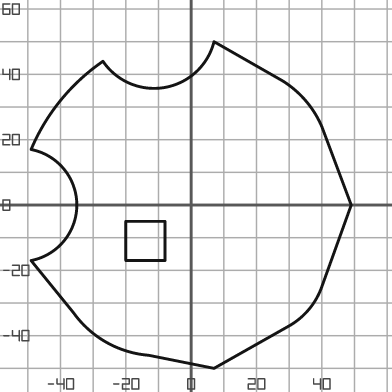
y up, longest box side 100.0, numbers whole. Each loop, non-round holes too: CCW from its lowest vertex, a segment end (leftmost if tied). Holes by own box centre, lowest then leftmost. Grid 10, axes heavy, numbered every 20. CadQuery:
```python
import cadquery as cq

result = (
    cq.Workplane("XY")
    .moveTo(7.0, -50.0)
    .lineTo(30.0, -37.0)
    .threePointArc((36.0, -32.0), (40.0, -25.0))
    .lineTo(49.0, 0.0)
    .lineTo(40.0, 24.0)
    .threePointArc((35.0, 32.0), (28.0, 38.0))
    .lineTo(7.0, 50.0)
    .threePointArc((-8.0, 36.0), (-27.0, 44.0))
    .threePointArc((-40.0, 32.0), (-49.0, 17.0))
    .threePointArc((-35.0, 0.0), (-49.0, -17.0))
    .lineTo(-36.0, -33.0)
    .threePointArc((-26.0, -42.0), (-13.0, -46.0))
    .close()
    .moveTo(-20.0, -17.0)
    .lineTo(-8.0, -17.0)
    .lineTo(-8.0, -5.0)
    .lineTo(-20.0, -5.0)
    .close()
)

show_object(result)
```